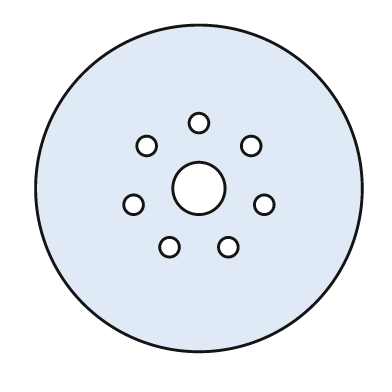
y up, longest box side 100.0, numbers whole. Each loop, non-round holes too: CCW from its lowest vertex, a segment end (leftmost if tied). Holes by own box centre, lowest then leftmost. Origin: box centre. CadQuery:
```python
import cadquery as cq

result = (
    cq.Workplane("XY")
    .moveTo(0.0, 0.0)
    .circle(50.0)
    .moveTo(-9.0, -18.0)
    .circle(3.0)
    .moveTo(9.0, -18.0)
    .circle(3.0)
    .moveTo(-20.0, -5.0)
    .circle(3.0)
    .moveTo(20.0, -5.0)
    .circle(3.0)
    .moveTo(0.0, 0.0)
    .circle(8.0)
    .moveTo(-16.0, 13.0)
    .circle(3.0)
    .moveTo(16.0, 13.0)
    .circle(3.0)
    .moveTo(0.0, 20.0)
    .circle(3.0)
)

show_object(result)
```